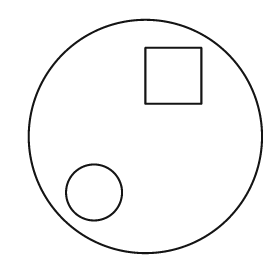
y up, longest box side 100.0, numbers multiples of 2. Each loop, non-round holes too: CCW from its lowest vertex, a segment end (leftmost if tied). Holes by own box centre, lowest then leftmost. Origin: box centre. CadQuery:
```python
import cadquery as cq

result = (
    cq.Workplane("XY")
    .moveTo(0.0, 0.0)
    .circle(50.0)
    .moveTo(-22.0, -24.0)
    .circle(12.0)
    .moveTo(0.0, 14.0)
    .lineTo(24.0, 14.0)
    .lineTo(24.0, 38.0)
    .lineTo(0.0, 38.0)
    .close()
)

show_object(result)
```